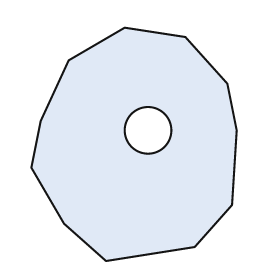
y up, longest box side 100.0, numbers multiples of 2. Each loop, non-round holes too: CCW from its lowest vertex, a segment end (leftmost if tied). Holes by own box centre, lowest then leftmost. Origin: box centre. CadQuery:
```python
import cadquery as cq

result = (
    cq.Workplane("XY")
    .moveTo(-12.0, -50.0)
    .lineTo(26.0, -44.0)
    .lineTo(42.0, -26.0)
    .lineTo(44.0, 6.0)
    .lineTo(40.0, 26.0)
    .lineTo(22.0, 46.0)
    .lineTo(-4.0, 50.0)
    .lineTo(-28.0, 36.0)
    .lineTo(-40.0, 10.0)
    .lineTo(-44.0, -10.0)
    .lineTo(-30.0, -34.0)
    .close()
    .moveTo(6.0, 6.0)
    .circle(10.0)
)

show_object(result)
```